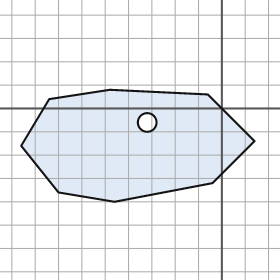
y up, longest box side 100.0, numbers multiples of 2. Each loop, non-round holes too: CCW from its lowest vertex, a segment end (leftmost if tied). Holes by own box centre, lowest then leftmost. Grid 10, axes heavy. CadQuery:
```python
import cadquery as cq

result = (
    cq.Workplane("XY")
    .moveTo(-46.0, -40.0)
    .lineTo(-4.0, -32.0)
    .lineTo(14.0, -14.0)
    .lineTo(-6.0, 6.0)
    .lineTo(-48.0, 8.0)
    .lineTo(-74.0, 4.0)
    .lineTo(-86.0, -16.0)
    .lineTo(-70.0, -36.0)
    .close()
    .moveTo(-32.0, -6.0)
    .circle(4.0)
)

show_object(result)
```